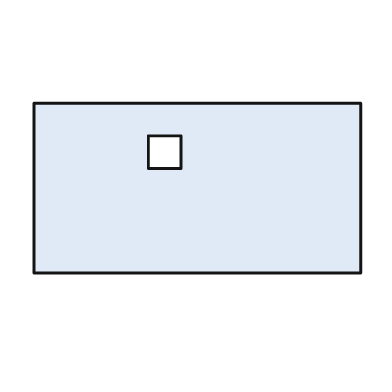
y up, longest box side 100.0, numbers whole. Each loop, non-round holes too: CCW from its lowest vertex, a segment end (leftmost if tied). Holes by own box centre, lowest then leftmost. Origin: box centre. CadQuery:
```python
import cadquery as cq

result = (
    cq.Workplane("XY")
    .moveTo(-50.0, -26.0)
    .lineTo(50.0, -26.0)
    .lineTo(50.0, 26.0)
    .lineTo(-50.0, 26.0)
    .close()
    .moveTo(-15.0, 6.0)
    .lineTo(-5.0, 6.0)
    .lineTo(-5.0, 16.0)
    .lineTo(-15.0, 16.0)
    .close()
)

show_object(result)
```